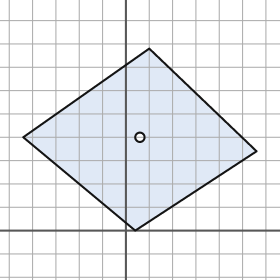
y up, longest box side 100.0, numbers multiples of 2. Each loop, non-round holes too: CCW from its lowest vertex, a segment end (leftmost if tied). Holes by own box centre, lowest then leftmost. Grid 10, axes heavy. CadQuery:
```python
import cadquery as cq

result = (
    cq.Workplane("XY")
    .moveTo(4.0, 0.0)
    .lineTo(56.0, 34.0)
    .lineTo(10.0, 78.0)
    .lineTo(-44.0, 40.0)
    .close()
    .moveTo(6.0, 40.0)
    .circle(2.0)
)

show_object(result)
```